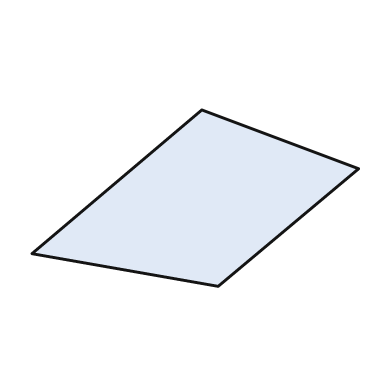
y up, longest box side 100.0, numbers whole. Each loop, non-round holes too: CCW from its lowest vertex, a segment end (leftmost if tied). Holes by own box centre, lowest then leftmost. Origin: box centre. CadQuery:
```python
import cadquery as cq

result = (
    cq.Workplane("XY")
    .moveTo(7.0, -27.0)
    .lineTo(50.0, 9.0)
    .lineTo(2.0, 27.0)
    .lineTo(-50.0, -17.0)
    .close()
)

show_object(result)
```